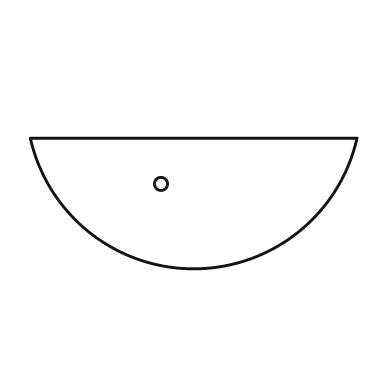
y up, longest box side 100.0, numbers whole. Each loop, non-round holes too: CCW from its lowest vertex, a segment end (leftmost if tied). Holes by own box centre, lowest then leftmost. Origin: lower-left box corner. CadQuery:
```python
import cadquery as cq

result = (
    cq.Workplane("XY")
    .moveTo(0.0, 40.0)
    .threePointArc((50.0, 0.0), (100.0, 40.0))
    .close()
    .moveTo(40.0, 26.0)
    .circle(2.0)
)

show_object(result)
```